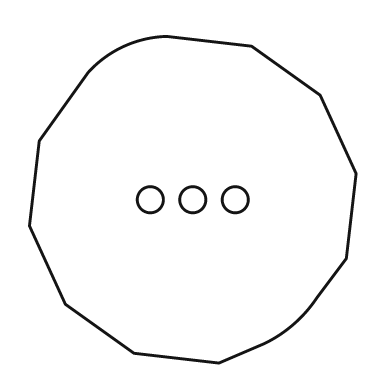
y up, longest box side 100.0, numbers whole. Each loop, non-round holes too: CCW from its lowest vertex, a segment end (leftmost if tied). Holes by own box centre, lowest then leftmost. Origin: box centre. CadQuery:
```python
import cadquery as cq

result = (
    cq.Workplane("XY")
    .moveTo(8.0, -50.0)
    .lineTo(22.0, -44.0)
    .threePointArc((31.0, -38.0), (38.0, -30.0))
    .lineTo(47.0, -18.0)
    .lineTo(50.0, 8.0)
    .lineTo(39.0, 32.0)
    .lineTo(18.0, 47.0)
    .lineTo(-8.0, 50.0)
    .threePointArc((-21.0, 47.0), (-32.0, 39.0))
    .lineTo(-47.0, 18.0)
    .lineTo(-50.0, -8.0)
    .lineTo(-39.0, -32.0)
    .lineTo(-18.0, -47.0)
    .close()
    .moveTo(-13.0, 0.0)
    .circle(4.0)
    .moveTo(0.0, 0.0)
    .circle(4.0)
    .moveTo(13.0, 0.0)
    .circle(4.0)
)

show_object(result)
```